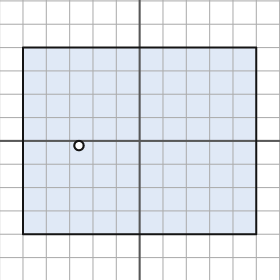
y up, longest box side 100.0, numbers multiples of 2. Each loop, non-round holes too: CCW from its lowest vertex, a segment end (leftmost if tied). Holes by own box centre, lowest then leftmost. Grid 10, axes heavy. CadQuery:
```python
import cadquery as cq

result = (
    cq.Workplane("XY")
    .moveTo(-50.0, -40.0)
    .lineTo(50.0, -40.0)
    .lineTo(50.0, 40.0)
    .lineTo(-50.0, 40.0)
    .close()
    .moveTo(-26.0, -2.0)
    .circle(2.0)
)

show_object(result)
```